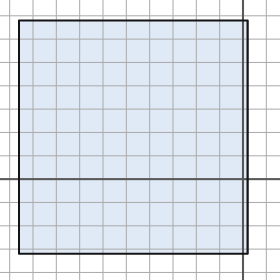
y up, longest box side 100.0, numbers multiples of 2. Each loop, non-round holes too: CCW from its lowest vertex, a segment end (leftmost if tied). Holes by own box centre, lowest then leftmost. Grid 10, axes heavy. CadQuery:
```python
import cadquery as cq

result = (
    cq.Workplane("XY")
    .moveTo(-96.0, -32.0)
    .lineTo(2.0, -32.0)
    .lineTo(2.0, 68.0)
    .lineTo(-96.0, 68.0)
    .close()
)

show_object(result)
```